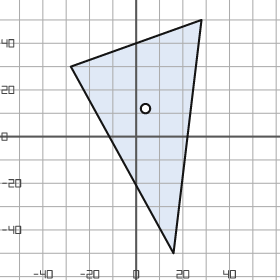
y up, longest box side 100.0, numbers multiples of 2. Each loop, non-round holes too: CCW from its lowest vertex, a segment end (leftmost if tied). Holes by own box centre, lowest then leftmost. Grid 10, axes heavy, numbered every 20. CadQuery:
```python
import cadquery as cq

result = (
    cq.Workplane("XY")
    .moveTo(16.0, -50.0)
    .lineTo(28.0, 50.0)
    .lineTo(-28.0, 30.0)
    .close()
    .moveTo(4.0, 12.0)
    .circle(2.0)
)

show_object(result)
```